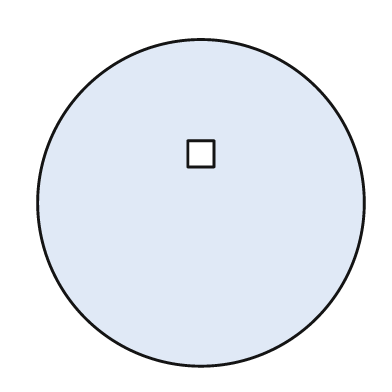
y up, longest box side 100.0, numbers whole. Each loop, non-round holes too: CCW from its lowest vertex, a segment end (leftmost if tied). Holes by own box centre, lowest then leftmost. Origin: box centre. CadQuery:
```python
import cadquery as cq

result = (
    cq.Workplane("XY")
    .moveTo(0.0, 0.0)
    .circle(50.0)
    .moveTo(-4.0, 11.0)
    .lineTo(4.0, 11.0)
    .lineTo(4.0, 19.0)
    .lineTo(-4.0, 19.0)
    .close()
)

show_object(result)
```